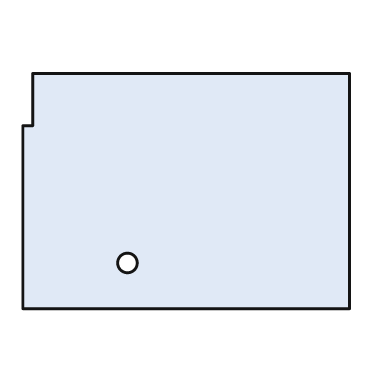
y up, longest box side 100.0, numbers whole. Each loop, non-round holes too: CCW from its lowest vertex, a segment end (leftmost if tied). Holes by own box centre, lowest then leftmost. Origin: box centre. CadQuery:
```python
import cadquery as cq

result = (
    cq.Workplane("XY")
    .moveTo(-50.0, -36.0)
    .lineTo(50.0, -36.0)
    .lineTo(50.0, 36.0)
    .lineTo(-47.0, 36.0)
    .lineTo(-47.0, 20.0)
    .lineTo(-50.0, 20.0)
    .close()
    .moveTo(-18.0, -22.0)
    .circle(3.0)
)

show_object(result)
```